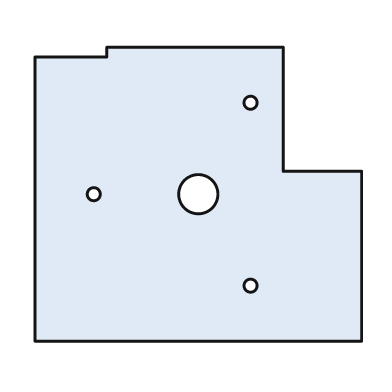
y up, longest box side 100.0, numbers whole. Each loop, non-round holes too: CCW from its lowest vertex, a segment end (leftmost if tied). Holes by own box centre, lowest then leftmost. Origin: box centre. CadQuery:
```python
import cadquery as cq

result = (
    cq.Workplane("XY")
    .moveTo(-50.0, -45.0)
    .lineTo(50.0, -45.0)
    .lineTo(50.0, 7.0)
    .lineTo(26.0, 7.0)
    .lineTo(26.0, 45.0)
    .lineTo(-28.0, 45.0)
    .lineTo(-28.0, 42.0)
    .lineTo(-50.0, 42.0)
    .close()
    .moveTo(16.0, -28.0)
    .circle(2.0)
    .moveTo(-32.0, 0.0)
    .circle(2.0)
    .moveTo(0.0, 0.0)
    .circle(6.0)
    .moveTo(16.0, 28.0)
    .circle(2.0)
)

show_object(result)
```